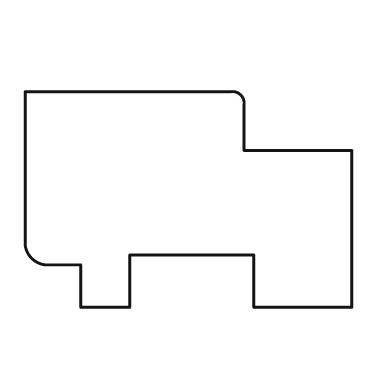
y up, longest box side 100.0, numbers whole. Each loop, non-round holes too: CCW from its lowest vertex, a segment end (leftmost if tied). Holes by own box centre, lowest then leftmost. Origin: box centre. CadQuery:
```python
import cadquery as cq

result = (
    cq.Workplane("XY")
    .moveTo(-33.0, -33.0)
    .lineTo(-18.0, -33.0)
    .lineTo(-18.0, -17.0)
    .lineTo(20.0, -17.0)
    .lineTo(20.0, -33.0)
    .lineTo(50.0, -33.0)
    .lineTo(50.0, 15.0)
    .lineTo(17.0, 15.0)
    .lineTo(17.0, 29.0)
    .threePointArc((16.0, 32.0), (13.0, 33.0))
    .lineTo(-50.0, 33.0)
    .lineTo(-50.0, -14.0)
    .threePointArc((-48.0, -18.0), (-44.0, -20.0))
    .lineTo(-33.0, -20.0)
    .close()
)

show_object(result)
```